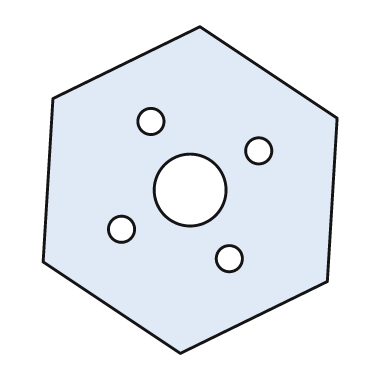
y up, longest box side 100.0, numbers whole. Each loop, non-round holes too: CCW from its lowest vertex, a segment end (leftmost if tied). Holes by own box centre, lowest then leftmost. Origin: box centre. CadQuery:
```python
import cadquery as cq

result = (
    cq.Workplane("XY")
    .moveTo(-3.0, -50.0)
    .lineTo(42.0, -28.0)
    .lineTo(45.0, 22.0)
    .lineTo(3.0, 50.0)
    .lineTo(-42.0, 28.0)
    .lineTo(-45.0, -22.0)
    .close()
    .moveTo(12.0, -21.0)
    .circle(4.0)
    .moveTo(-21.0, -12.0)
    .circle(4.0)
    .moveTo(0.0, 0.0)
    .circle(11.0)
    .moveTo(21.0, 12.0)
    .circle(4.0)
    .moveTo(-12.0, 21.0)
    .circle(4.0)
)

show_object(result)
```